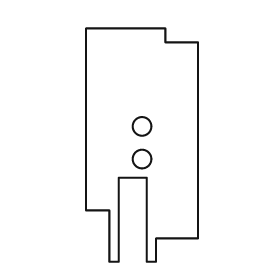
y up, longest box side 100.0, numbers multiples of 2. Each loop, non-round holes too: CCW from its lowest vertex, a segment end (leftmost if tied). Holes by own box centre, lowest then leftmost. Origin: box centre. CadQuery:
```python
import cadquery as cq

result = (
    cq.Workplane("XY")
    .moveTo(-14.0, -50.0)
    .lineTo(-10.0, -50.0)
    .lineTo(-10.0, -14.0)
    .lineTo(2.0, -14.0)
    .lineTo(2.0, -50.0)
    .lineTo(6.0, -50.0)
    .lineTo(6.0, -40.0)
    .lineTo(24.0, -40.0)
    .lineTo(24.0, 44.0)
    .lineTo(10.0, 44.0)
    .lineTo(10.0, 50.0)
    .lineTo(-24.0, 50.0)
    .lineTo(-24.0, -28.0)
    .lineTo(-14.0, -28.0)
    .close()
    .moveTo(0.0, -6.0)
    .circle(4.0)
    .moveTo(0.0, 8.0)
    .circle(4.0)
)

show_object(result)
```